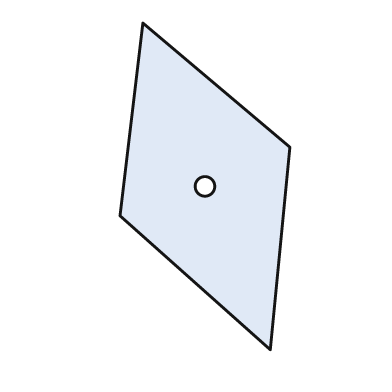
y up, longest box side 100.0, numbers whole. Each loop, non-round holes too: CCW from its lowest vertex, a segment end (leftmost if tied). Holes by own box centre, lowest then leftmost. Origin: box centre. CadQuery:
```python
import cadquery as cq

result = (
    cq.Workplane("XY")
    .moveTo(20.0, -50.0)
    .lineTo(26.0, 12.0)
    .lineTo(-19.0, 50.0)
    .lineTo(-26.0, -9.0)
    .close()
    .moveTo(0.0, 0.0)
    .circle(3.0)
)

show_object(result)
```